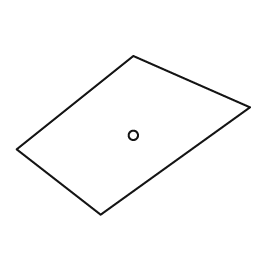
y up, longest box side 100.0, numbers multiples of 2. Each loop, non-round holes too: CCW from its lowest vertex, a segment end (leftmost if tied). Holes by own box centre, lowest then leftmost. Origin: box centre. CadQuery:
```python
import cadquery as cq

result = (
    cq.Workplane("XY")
    .moveTo(-14.0, -34.0)
    .lineTo(50.0, 12.0)
    .lineTo(0.0, 34.0)
    .lineTo(-50.0, -6.0)
    .close()
    .moveTo(0.0, 0.0)
    .circle(2.0)
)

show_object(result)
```